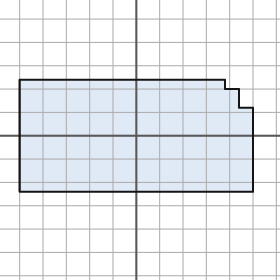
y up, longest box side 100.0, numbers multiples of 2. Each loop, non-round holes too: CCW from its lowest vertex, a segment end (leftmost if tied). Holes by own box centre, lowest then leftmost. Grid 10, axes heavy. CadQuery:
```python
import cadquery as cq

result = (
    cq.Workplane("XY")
    .moveTo(-50.0, -24.0)
    .lineTo(50.0, -24.0)
    .lineTo(50.0, 12.0)
    .lineTo(44.0, 12.0)
    .lineTo(44.0, 20.0)
    .lineTo(38.0, 20.0)
    .lineTo(38.0, 24.0)
    .lineTo(-50.0, 24.0)
    .close()
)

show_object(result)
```